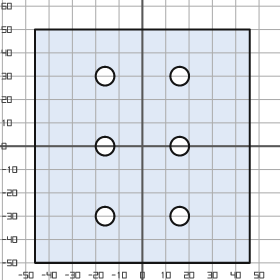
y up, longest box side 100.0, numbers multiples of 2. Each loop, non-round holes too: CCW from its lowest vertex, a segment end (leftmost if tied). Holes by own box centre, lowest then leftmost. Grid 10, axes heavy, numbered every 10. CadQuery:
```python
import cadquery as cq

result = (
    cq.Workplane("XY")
    .moveTo(-46.0, -50.0)
    .lineTo(46.0, -50.0)
    .lineTo(46.0, 50.0)
    .lineTo(-46.0, 50.0)
    .close()
    .moveTo(-16.0, -30.0)
    .circle(4.0)
    .moveTo(16.0, -30.0)
    .circle(4.0)
    .moveTo(-16.0, 0.0)
    .circle(4.0)
    .moveTo(16.0, 0.0)
    .circle(4.0)
    .moveTo(-16.0, 30.0)
    .circle(4.0)
    .moveTo(16.0, 30.0)
    .circle(4.0)
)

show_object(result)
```